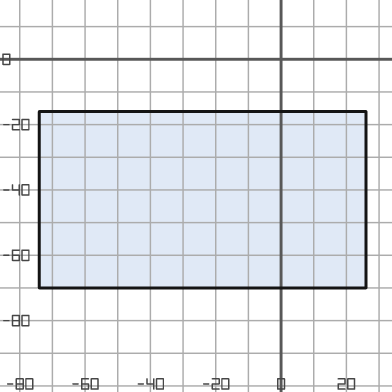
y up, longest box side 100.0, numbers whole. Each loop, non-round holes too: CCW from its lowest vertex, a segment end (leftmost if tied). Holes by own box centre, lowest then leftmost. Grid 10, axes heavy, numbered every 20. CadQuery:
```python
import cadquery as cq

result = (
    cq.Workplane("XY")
    .moveTo(-74.0, -70.0)
    .lineTo(26.0, -70.0)
    .lineTo(26.0, -16.0)
    .lineTo(-74.0, -16.0)
    .close()
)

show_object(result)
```